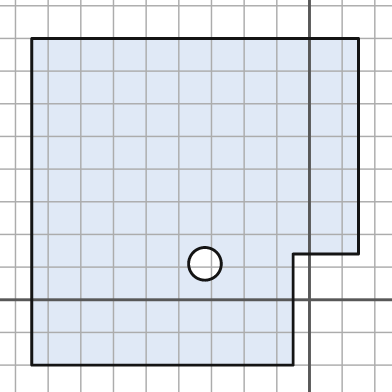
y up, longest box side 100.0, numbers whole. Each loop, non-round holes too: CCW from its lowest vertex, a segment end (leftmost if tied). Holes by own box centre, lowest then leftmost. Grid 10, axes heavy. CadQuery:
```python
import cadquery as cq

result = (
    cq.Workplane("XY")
    .moveTo(-85.0, -20.0)
    .lineTo(-5.0, -20.0)
    .lineTo(-5.0, 14.0)
    .lineTo(15.0, 14.0)
    .lineTo(15.0, 80.0)
    .lineTo(-85.0, 80.0)
    .close()
    .moveTo(-32.0, 11.0)
    .circle(5.0)
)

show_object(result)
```